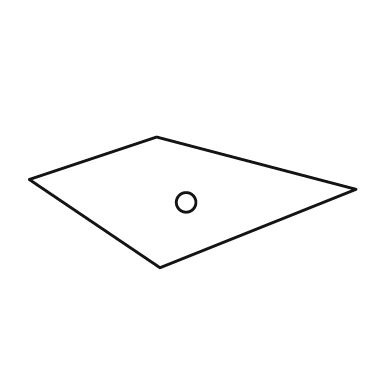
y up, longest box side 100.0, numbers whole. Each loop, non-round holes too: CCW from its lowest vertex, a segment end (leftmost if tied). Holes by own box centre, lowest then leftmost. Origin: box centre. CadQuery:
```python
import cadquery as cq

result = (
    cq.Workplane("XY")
    .moveTo(-10.0, -20.0)
    .lineTo(50.0, 4.0)
    .lineTo(-11.0, 20.0)
    .lineTo(-50.0, 7.0)
    .close()
    .moveTo(-2.0, 0.0)
    .circle(3.0)
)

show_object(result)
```